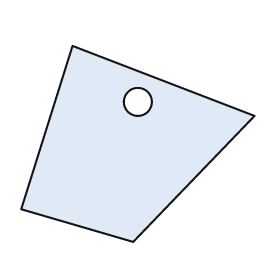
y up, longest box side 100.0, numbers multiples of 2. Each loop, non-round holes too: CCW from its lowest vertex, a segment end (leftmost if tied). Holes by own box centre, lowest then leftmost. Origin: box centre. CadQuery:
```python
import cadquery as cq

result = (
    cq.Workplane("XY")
    .moveTo(-2.0, -42.0)
    .lineTo(50.0, 12.0)
    .lineTo(-28.0, 42.0)
    .lineTo(-50.0, -28.0)
    .close()
    .moveTo(0.0, 18.0)
    .circle(6.0)
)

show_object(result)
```